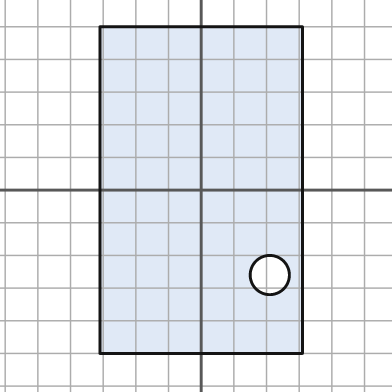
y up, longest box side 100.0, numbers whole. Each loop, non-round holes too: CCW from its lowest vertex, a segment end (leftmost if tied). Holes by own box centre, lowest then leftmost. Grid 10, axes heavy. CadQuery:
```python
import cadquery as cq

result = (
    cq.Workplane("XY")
    .moveTo(-31.0, -50.0)
    .lineTo(31.0, -50.0)
    .lineTo(31.0, 50.0)
    .lineTo(-31.0, 50.0)
    .close()
    .moveTo(21.0, -26.0)
    .circle(6.0)
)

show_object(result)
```